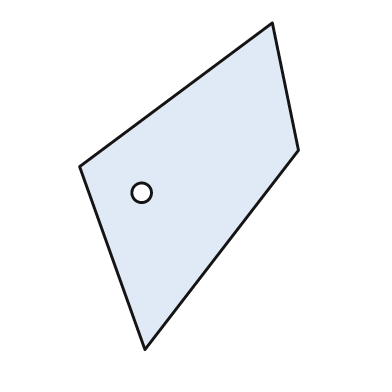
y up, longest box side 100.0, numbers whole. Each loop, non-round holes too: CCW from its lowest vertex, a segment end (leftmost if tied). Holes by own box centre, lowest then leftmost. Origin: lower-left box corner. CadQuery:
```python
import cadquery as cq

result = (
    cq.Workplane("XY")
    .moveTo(20.0, 0.0)
    .lineTo(67.0, 61.0)
    .lineTo(59.0, 100.0)
    .lineTo(0.0, 56.0)
    .close()
    .moveTo(19.0, 48.0)
    .circle(3.0)
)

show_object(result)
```